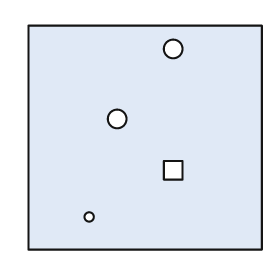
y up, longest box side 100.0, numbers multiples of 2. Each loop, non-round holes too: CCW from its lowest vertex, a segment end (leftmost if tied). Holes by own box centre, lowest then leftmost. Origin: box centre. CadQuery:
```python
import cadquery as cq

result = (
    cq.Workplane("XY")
    .moveTo(-50.0, -48.0)
    .lineTo(50.0, -48.0)
    .lineTo(50.0, 48.0)
    .lineTo(-50.0, 48.0)
    .close()
    .moveTo(-24.0, -34.0)
    .circle(2.0)
    .moveTo(8.0, -18.0)
    .lineTo(16.0, -18.0)
    .lineTo(16.0, -10.0)
    .lineTo(8.0, -10.0)
    .close()
    .moveTo(-12.0, 8.0)
    .circle(4.0)
    .moveTo(12.0, 38.0)
    .circle(4.0)
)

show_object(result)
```